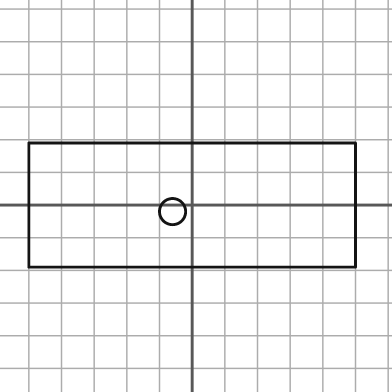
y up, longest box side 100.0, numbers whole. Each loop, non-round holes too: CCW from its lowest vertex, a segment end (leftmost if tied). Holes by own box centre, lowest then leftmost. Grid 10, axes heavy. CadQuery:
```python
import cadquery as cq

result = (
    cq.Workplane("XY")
    .moveTo(-50.0, -19.0)
    .lineTo(50.0, -19.0)
    .lineTo(50.0, 19.0)
    .lineTo(-50.0, 19.0)
    .close()
    .moveTo(-6.0, -2.0)
    .circle(4.0)
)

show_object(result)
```